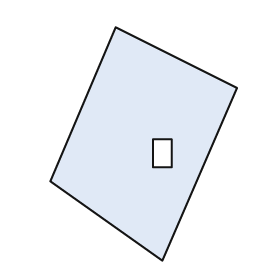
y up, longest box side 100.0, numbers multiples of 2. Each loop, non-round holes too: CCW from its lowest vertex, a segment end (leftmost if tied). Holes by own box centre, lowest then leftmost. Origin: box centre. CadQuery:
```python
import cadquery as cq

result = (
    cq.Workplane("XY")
    .moveTo(8.0, -50.0)
    .lineTo(40.0, 24.0)
    .lineTo(-12.0, 50.0)
    .lineTo(-40.0, -16.0)
    .close()
    .moveTo(4.0, -10.0)
    .lineTo(12.0, -10.0)
    .lineTo(12.0, 2.0)
    .lineTo(4.0, 2.0)
    .close()
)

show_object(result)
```